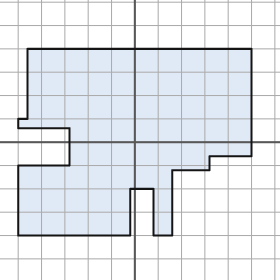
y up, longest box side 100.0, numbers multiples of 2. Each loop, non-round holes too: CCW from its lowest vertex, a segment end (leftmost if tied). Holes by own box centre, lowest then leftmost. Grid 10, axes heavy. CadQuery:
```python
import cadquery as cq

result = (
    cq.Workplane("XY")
    .moveTo(-50.0, -40.0)
    .lineTo(-2.0, -40.0)
    .lineTo(-2.0, -20.0)
    .lineTo(8.0, -20.0)
    .lineTo(8.0, -40.0)
    .lineTo(16.0, -40.0)
    .lineTo(16.0, -12.0)
    .lineTo(32.0, -12.0)
    .lineTo(32.0, -6.0)
    .lineTo(50.0, -6.0)
    .lineTo(50.0, 40.0)
    .lineTo(-46.0, 40.0)
    .lineTo(-46.0, 10.0)
    .lineTo(-50.0, 10.0)
    .lineTo(-50.0, 6.0)
    .lineTo(-28.0, 6.0)
    .lineTo(-28.0, -10.0)
    .lineTo(-50.0, -10.0)
    .close()
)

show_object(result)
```